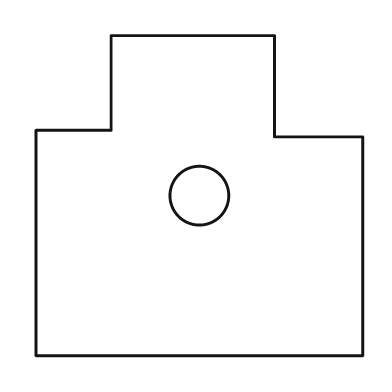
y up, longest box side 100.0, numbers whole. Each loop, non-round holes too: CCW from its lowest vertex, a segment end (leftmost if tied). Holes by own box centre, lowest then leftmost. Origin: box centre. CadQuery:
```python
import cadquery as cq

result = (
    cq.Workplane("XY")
    .moveTo(-50.0, -49.0)
    .lineTo(50.0, -49.0)
    .lineTo(50.0, 18.0)
    .lineTo(23.0, 18.0)
    .lineTo(23.0, 49.0)
    .lineTo(-27.0, 49.0)
    .lineTo(-27.0, 20.0)
    .lineTo(-50.0, 20.0)
    .close()
    .moveTo(0.0, 0.0)
    .circle(9.0)
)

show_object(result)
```